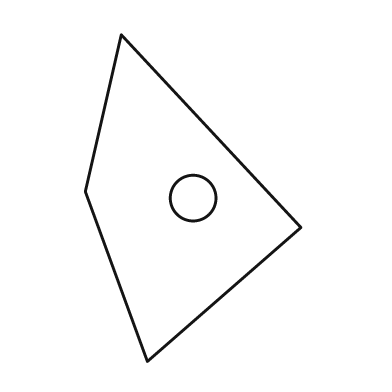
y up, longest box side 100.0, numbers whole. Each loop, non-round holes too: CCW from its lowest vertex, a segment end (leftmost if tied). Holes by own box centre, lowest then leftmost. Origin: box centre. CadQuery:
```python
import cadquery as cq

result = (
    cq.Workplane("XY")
    .moveTo(-14.0, -50.0)
    .lineTo(33.0, -9.0)
    .lineTo(-22.0, 50.0)
    .lineTo(-33.0, 2.0)
    .close()
    .moveTo(0.0, 0.0)
    .circle(7.0)
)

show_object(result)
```